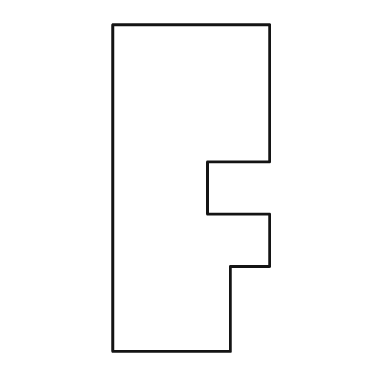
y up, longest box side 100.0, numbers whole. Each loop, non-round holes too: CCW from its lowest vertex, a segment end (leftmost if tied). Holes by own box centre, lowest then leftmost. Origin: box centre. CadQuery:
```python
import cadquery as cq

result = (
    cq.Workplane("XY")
    .moveTo(-24.0, -50.0)
    .lineTo(12.0, -50.0)
    .lineTo(12.0, -24.0)
    .lineTo(24.0, -24.0)
    .lineTo(24.0, -8.0)
    .lineTo(5.0, -8.0)
    .lineTo(5.0, 8.0)
    .lineTo(24.0, 8.0)
    .lineTo(24.0, 50.0)
    .lineTo(-24.0, 50.0)
    .close()
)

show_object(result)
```